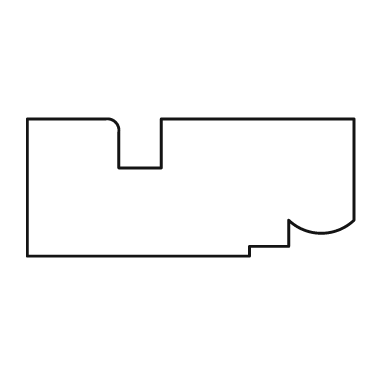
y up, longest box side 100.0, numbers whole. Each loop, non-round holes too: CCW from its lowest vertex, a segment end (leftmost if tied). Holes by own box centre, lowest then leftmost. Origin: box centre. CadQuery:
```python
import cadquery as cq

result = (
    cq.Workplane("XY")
    .moveTo(-50.0, -21.0)
    .lineTo(18.0, -21.0)
    .lineTo(18.0, -18.0)
    .lineTo(30.0, -18.0)
    .lineTo(30.0, -10.0)
    .threePointArc((40.0, -14.0), (50.0, -10.0))
    .lineTo(50.0, 21.0)
    .lineTo(-9.0, 21.0)
    .lineTo(-9.0, 6.0)
    .lineTo(-22.0, 6.0)
    .lineTo(-22.0, 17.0)
    .threePointArc((-23.0, 20.0), (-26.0, 21.0))
    .lineTo(-50.0, 21.0)
    .close()
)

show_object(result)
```